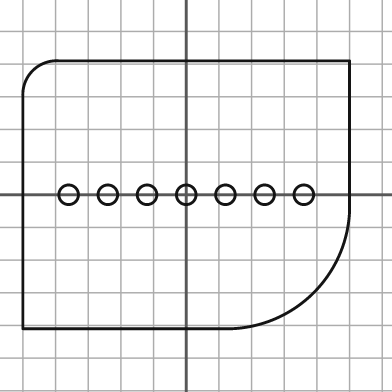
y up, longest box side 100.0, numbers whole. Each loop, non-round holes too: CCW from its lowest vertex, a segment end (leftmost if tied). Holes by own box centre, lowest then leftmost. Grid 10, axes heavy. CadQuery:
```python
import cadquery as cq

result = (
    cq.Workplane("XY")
    .moveTo(-50.0, -41.0)
    .lineTo(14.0, -41.0)
    .threePointArc((39.0, -30.0), (50.0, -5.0))
    .lineTo(50.0, 41.0)
    .lineTo(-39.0, 41.0)
    .threePointArc((-47.0, 38.0), (-50.0, 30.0))
    .close()
    .moveTo(-36.0, 0.0)
    .circle(3.0)
    .moveTo(-24.0, 0.0)
    .circle(3.0)
    .moveTo(-12.0, 0.0)
    .circle(3.0)
    .moveTo(0.0, 0.0)
    .circle(3.0)
    .moveTo(12.0, 0.0)
    .circle(3.0)
    .moveTo(24.0, 0.0)
    .circle(3.0)
    .moveTo(36.0, 0.0)
    .circle(3.0)
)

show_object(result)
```